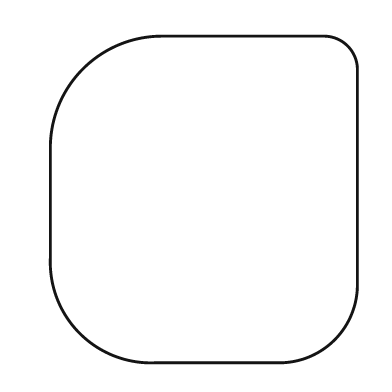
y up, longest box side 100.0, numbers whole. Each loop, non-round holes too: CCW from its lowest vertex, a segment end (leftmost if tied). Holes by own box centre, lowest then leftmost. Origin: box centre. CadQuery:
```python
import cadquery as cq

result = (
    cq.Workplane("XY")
    .moveTo(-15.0, -50.0)
    .lineTo(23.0, -50.0)
    .threePointArc((40.0, -43.0), (47.0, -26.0))
    .lineTo(47.0, 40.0)
    .threePointArc((44.0, 47.0), (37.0, 50.0))
    .lineTo(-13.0, 50.0)
    .threePointArc((-37.0, 40.0), (-47.0, 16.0))
    .lineTo(-47.0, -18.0)
    .threePointArc((-38.0, -41.0), (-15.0, -50.0))
    .close()
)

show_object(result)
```